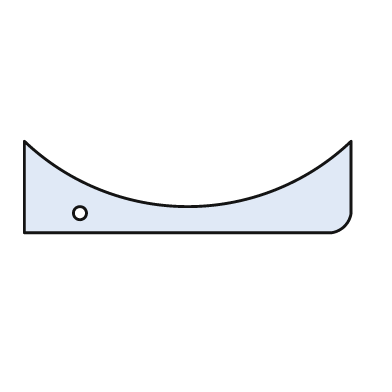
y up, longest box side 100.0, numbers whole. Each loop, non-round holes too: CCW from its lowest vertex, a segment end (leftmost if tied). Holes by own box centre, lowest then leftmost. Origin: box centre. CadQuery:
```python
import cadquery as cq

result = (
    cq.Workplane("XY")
    .moveTo(-50.0, -14.0)
    .lineTo(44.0, -14.0)
    .threePointArc((48.0, -12.0), (50.0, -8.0))
    .lineTo(50.0, 14.0)
    .threePointArc((0.0, -6.0), (-50.0, 14.0))
    .close()
    .moveTo(-33.0, -8.0)
    .circle(2.0)
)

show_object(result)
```